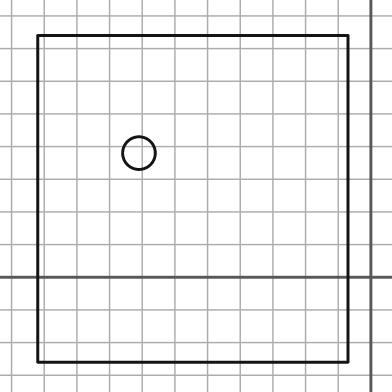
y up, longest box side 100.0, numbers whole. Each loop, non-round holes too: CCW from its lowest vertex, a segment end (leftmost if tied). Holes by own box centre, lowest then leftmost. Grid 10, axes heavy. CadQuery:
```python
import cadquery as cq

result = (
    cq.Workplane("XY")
    .moveTo(-102.0, -26.0)
    .lineTo(-7.0, -26.0)
    .lineTo(-7.0, 74.0)
    .lineTo(-102.0, 74.0)
    .close()
    .moveTo(-71.0, 38.0)
    .circle(5.0)
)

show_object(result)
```